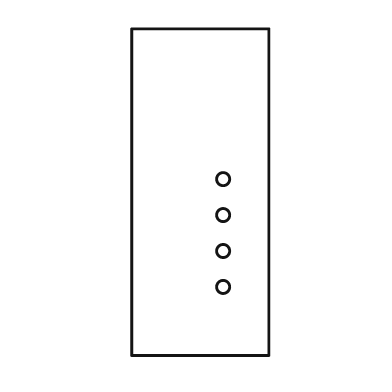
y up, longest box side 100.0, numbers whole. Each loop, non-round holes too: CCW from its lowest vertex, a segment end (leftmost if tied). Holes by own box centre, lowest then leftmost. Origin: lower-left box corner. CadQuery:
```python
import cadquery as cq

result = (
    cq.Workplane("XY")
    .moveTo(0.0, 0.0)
    .lineTo(42.0, 0.0)
    .lineTo(42.0, 100.0)
    .lineTo(0.0, 100.0)
    .close()
    .moveTo(28.0, 21.0)
    .circle(2.0)
    .moveTo(28.0, 32.0)
    .circle(2.0)
    .moveTo(28.0, 43.0)
    .circle(2.0)
    .moveTo(28.0, 54.0)
    .circle(2.0)
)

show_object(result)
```